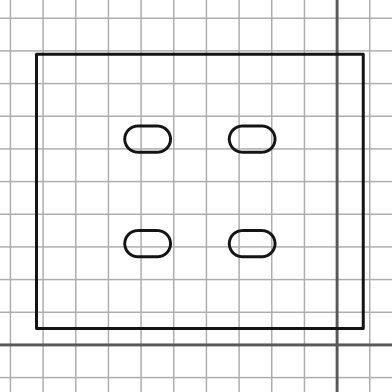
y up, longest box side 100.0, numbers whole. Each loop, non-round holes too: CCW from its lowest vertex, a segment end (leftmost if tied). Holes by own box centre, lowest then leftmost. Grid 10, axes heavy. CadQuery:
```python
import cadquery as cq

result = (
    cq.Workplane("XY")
    .moveTo(-92.0, 5.0)
    .lineTo(8.0, 5.0)
    .lineTo(8.0, 89.0)
    .lineTo(-92.0, 89.0)
    .close()
    .moveTo(-61.0, 27.0)
    .lineTo(-55.0, 27.0)
    .threePointArc((-51.0, 31.0), (-55.0, 35.0))
    .lineTo(-61.0, 35.0)
    .threePointArc((-65.0, 31.0), (-61.0, 27.0))
    .close()
    .moveTo(-29.0, 27.0)
    .lineTo(-23.0, 27.0)
    .threePointArc((-19.0, 31.0), (-23.0, 35.0))
    .lineTo(-29.0, 35.0)
    .threePointArc((-33.0, 31.0), (-29.0, 27.0))
    .close()
    .moveTo(-61.0, 59.0)
    .lineTo(-55.0, 59.0)
    .threePointArc((-51.0, 63.0), (-55.0, 67.0))
    .lineTo(-61.0, 67.0)
    .threePointArc((-65.0, 63.0), (-61.0, 59.0))
    .close()
    .moveTo(-29.0, 59.0)
    .lineTo(-23.0, 59.0)
    .threePointArc((-19.0, 63.0), (-23.0, 67.0))
    .lineTo(-29.0, 67.0)
    .threePointArc((-33.0, 63.0), (-29.0, 59.0))
    .close()
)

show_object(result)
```